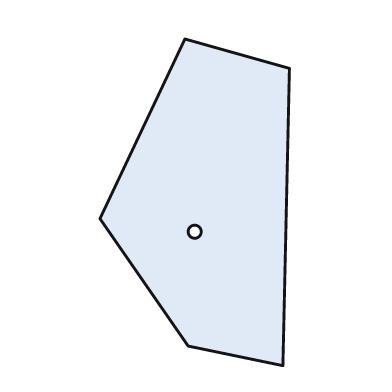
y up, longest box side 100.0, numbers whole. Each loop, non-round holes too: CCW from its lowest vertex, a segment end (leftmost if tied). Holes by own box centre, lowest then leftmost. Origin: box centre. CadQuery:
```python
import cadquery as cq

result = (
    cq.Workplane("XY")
    .moveTo(27.0, -50.0)
    .lineTo(29.0, 41.0)
    .lineTo(-3.0, 50.0)
    .lineTo(-29.0, -5.0)
    .lineTo(-2.0, -44.0)
    .close()
    .moveTo(0.0, -9.0)
    .circle(2.0)
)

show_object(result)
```